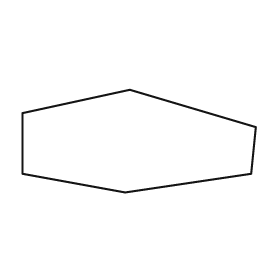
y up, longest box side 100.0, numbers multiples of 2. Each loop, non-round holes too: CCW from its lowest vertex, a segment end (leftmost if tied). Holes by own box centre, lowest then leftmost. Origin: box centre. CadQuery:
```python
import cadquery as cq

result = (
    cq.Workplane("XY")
    .moveTo(-6.0, -22.0)
    .lineTo(48.0, -14.0)
    .lineTo(50.0, 6.0)
    .lineTo(-4.0, 22.0)
    .lineTo(-50.0, 12.0)
    .lineTo(-50.0, -14.0)
    .close()
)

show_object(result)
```